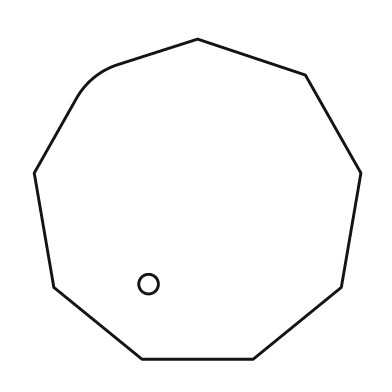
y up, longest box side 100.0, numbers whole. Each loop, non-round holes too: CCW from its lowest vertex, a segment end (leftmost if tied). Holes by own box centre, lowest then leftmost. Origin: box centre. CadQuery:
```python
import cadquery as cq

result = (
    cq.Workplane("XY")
    .moveTo(-17.0, -49.0)
    .lineTo(17.0, -49.0)
    .lineTo(44.0, -27.0)
    .lineTo(50.0, 8.0)
    .lineTo(33.0, 38.0)
    .lineTo(0.0, 49.0)
    .lineTo(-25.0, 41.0)
    .threePointArc((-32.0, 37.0), (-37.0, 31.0))
    .lineTo(-50.0, 8.0)
    .lineTo(-44.0, -27.0)
    .close()
    .moveTo(-15.0, -26.0)
    .circle(3.0)
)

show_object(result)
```